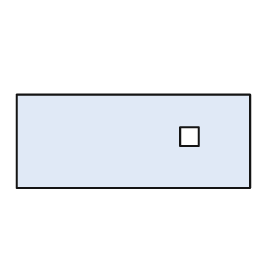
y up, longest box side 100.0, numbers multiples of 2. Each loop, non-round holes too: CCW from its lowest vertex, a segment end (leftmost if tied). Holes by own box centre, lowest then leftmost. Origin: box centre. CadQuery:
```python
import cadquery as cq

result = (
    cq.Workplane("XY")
    .moveTo(-50.0, -20.0)
    .lineTo(50.0, -20.0)
    .lineTo(50.0, 20.0)
    .lineTo(-50.0, 20.0)
    .close()
    .moveTo(20.0, -2.0)
    .lineTo(28.0, -2.0)
    .lineTo(28.0, 6.0)
    .lineTo(20.0, 6.0)
    .close()
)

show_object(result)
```